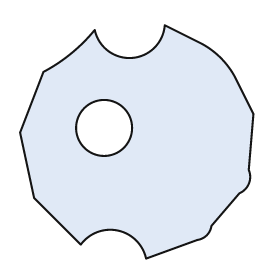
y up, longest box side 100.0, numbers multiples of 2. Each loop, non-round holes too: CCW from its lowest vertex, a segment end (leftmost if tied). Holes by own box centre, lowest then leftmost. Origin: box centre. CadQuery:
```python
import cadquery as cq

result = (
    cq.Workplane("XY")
    .moveTo(4.0, -50.0)
    .lineTo(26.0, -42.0)
    .threePointArc((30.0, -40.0), (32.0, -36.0))
    .lineTo(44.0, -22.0)
    .threePointArc((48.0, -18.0), (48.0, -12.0))
    .lineTo(50.0, 12.0)
    .lineTo(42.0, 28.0)
    .threePointArc((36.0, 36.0), (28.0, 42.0))
    .lineTo(12.0, 50.0)
    .threePointArc((-2.0, 36.0), (-18.0, 48.0))
    .threePointArc((-28.0, 38.0), (-40.0, 30.0))
    .lineTo(-50.0, 4.0)
    .lineTo(-44.0, -24.0)
    .lineTo(-24.0, -44.0)
    .threePointArc((-8.0, -38.0), (4.0, -50.0))
    .close()
    .moveTo(-14.0, 6.0)
    .circle(12.0)
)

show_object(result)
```